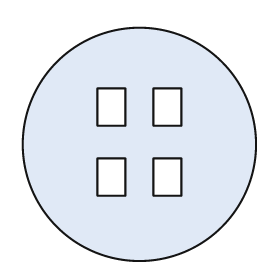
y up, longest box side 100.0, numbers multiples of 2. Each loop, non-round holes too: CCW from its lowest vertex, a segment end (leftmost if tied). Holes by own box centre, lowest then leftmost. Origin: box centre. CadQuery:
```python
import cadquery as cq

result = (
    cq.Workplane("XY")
    .moveTo(0.0, 0.0)
    .circle(50.0)
    .moveTo(-18.0, -22.0)
    .lineTo(-6.0, -22.0)
    .lineTo(-6.0, -6.0)
    .lineTo(-18.0, -6.0)
    .close()
    .moveTo(6.0, -22.0)
    .lineTo(18.0, -22.0)
    .lineTo(18.0, -6.0)
    .lineTo(6.0, -6.0)
    .close()
    .moveTo(-18.0, 8.0)
    .lineTo(-6.0, 8.0)
    .lineTo(-6.0, 24.0)
    .lineTo(-18.0, 24.0)
    .close()
    .moveTo(6.0, 8.0)
    .lineTo(18.0, 8.0)
    .lineTo(18.0, 24.0)
    .lineTo(6.0, 24.0)
    .close()
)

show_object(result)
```